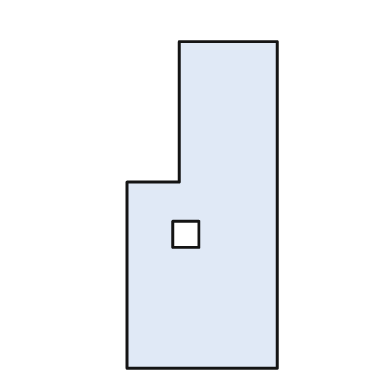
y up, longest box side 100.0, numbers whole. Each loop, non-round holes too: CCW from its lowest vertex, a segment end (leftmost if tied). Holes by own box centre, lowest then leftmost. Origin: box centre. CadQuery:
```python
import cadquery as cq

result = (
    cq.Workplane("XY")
    .moveTo(-23.0, -50.0)
    .lineTo(23.0, -50.0)
    .lineTo(23.0, 50.0)
    .lineTo(-7.0, 50.0)
    .lineTo(-7.0, 7.0)
    .lineTo(-23.0, 7.0)
    .close()
    .moveTo(-9.0, -13.0)
    .lineTo(-1.0, -13.0)
    .lineTo(-1.0, -5.0)
    .lineTo(-9.0, -5.0)
    .close()
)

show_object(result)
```